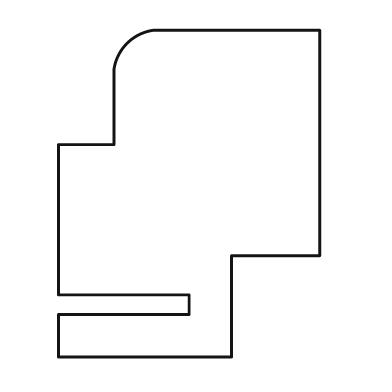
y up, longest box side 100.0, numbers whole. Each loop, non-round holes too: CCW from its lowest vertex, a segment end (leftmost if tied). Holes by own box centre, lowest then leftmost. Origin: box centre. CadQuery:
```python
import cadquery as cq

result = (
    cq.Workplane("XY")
    .moveTo(-40.0, -50.0)
    .lineTo(13.0, -50.0)
    .lineTo(13.0, -19.0)
    .lineTo(40.0, -19.0)
    .lineTo(40.0, 50.0)
    .lineTo(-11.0, 50.0)
    .threePointArc((-19.0, 46.0), (-23.0, 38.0))
    .lineTo(-23.0, 15.0)
    .lineTo(-40.0, 15.0)
    .lineTo(-40.0, -31.0)
    .lineTo(0.0, -31.0)
    .lineTo(0.0, -37.0)
    .lineTo(-40.0, -37.0)
    .close()
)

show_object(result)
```